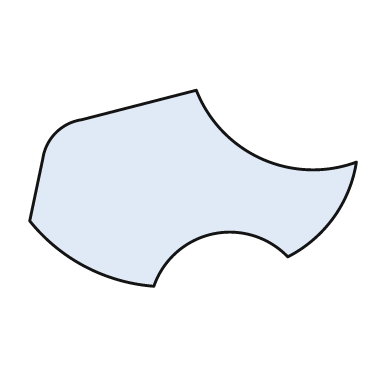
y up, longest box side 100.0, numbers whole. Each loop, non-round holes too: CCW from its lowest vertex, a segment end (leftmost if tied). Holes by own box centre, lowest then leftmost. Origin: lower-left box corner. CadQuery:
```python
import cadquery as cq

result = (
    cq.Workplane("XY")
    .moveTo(38.0, 0.0)
    .threePointArc((56.0, 16.0), (79.0, 9.0))
    .threePointArc((93.0, 21.0), (100.0, 38.0))
    .threePointArc((71.0, 39.0), (51.0, 60.0))
    .lineTo(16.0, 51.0)
    .threePointArc((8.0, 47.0), (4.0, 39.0))
    .lineTo(0.0, 20.0)
    .threePointArc((17.0, 6.0), (38.0, 0.0))
    .close()
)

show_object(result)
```